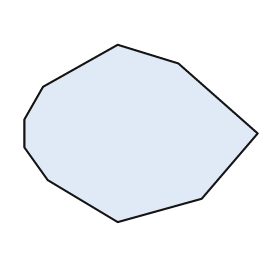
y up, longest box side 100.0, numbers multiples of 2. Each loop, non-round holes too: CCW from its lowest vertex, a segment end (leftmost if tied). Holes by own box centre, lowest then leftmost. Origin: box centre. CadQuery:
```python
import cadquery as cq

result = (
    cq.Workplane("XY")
    .moveTo(-10.0, -38.0)
    .lineTo(26.0, -28.0)
    .lineTo(50.0, 0.0)
    .lineTo(16.0, 30.0)
    .lineTo(-10.0, 38.0)
    .lineTo(-42.0, 20.0)
    .lineTo(-50.0, 6.0)
    .lineTo(-50.0, -6.0)
    .lineTo(-40.0, -20.0)
    .close()
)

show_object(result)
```